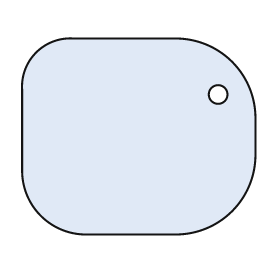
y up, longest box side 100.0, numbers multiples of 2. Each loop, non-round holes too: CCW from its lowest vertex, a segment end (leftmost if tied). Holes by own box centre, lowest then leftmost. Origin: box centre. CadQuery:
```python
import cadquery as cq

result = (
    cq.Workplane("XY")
    .moveTo(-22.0, -42.0)
    .lineTo(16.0, -42.0)
    .threePointArc((40.0, -32.0), (50.0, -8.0))
    .lineTo(50.0, 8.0)
    .threePointArc((40.0, 32.0), (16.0, 42.0))
    .lineTo(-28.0, 42.0)
    .threePointArc((-44.0, 36.0), (-50.0, 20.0))
    .lineTo(-50.0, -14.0)
    .threePointArc((-42.0, -34.0), (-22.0, -42.0))
    .close()
    .moveTo(34.0, 18.0)
    .circle(4.0)
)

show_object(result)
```